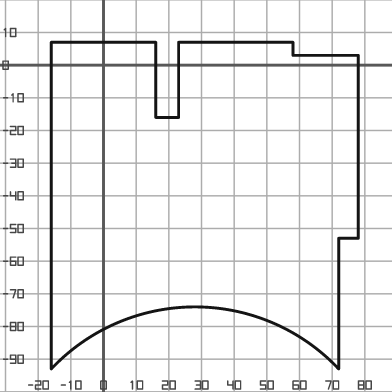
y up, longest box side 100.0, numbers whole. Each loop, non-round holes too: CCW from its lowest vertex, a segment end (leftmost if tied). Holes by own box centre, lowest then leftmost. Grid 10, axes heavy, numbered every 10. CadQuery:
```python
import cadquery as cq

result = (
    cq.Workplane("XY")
    .moveTo(-16.0, -93.0)
    .threePointArc((28.0, -74.0), (72.0, -93.0))
    .lineTo(72.0, -53.0)
    .lineTo(78.0, -53.0)
    .lineTo(78.0, 3.0)
    .lineTo(58.0, 3.0)
    .lineTo(58.0, 7.0)
    .lineTo(23.0, 7.0)
    .lineTo(23.0, -16.0)
    .lineTo(16.0, -16.0)
    .lineTo(16.0, 7.0)
    .lineTo(-16.0, 7.0)
    .close()
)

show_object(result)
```